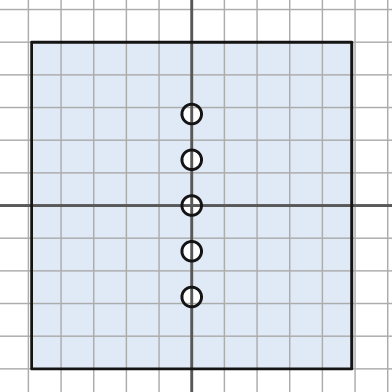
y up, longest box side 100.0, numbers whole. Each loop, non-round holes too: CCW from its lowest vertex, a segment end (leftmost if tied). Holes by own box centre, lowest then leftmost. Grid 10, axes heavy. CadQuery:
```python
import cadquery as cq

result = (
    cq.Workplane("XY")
    .moveTo(-49.0, -50.0)
    .lineTo(49.0, -50.0)
    .lineTo(49.0, 50.0)
    .lineTo(-49.0, 50.0)
    .close()
    .moveTo(0.0, -28.0)
    .circle(3.0)
    .moveTo(0.0, -14.0)
    .circle(3.0)
    .moveTo(0.0, 0.0)
    .circle(3.0)
    .moveTo(0.0, 14.0)
    .circle(3.0)
    .moveTo(0.0, 28.0)
    .circle(3.0)
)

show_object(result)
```